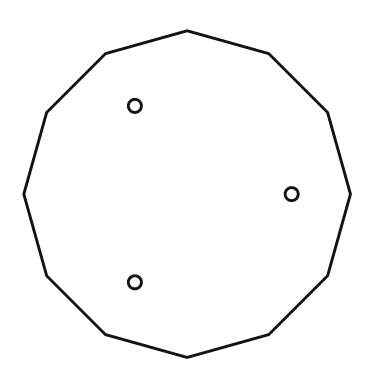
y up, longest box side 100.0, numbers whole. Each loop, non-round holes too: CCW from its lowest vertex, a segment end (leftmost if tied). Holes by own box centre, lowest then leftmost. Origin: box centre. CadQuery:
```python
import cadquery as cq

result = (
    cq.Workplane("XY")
    .moveTo(0.0, -50.0)
    .lineTo(25.0, -43.0)
    .lineTo(43.0, -25.0)
    .lineTo(50.0, 0.0)
    .lineTo(43.0, 25.0)
    .lineTo(25.0, 43.0)
    .lineTo(0.0, 50.0)
    .lineTo(-25.0, 43.0)
    .lineTo(-43.0, 25.0)
    .lineTo(-50.0, 0.0)
    .lineTo(-43.0, -25.0)
    .lineTo(-25.0, -43.0)
    .close()
    .moveTo(-16.0, -27.0)
    .circle(2.0)
    .moveTo(32.0, 0.0)
    .circle(2.0)
    .moveTo(-16.0, 27.0)
    .circle(2.0)
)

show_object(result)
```